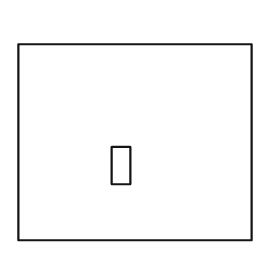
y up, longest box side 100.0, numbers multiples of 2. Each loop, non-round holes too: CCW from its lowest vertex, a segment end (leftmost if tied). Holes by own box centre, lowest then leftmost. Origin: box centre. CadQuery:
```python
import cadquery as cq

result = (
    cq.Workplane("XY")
    .moveTo(-50.0, -42.0)
    .lineTo(50.0, -42.0)
    .lineTo(50.0, 42.0)
    .lineTo(-50.0, 42.0)
    .close()
    .moveTo(-10.0, -18.0)
    .lineTo(-2.0, -18.0)
    .lineTo(-2.0, -2.0)
    .lineTo(-10.0, -2.0)
    .close()
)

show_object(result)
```